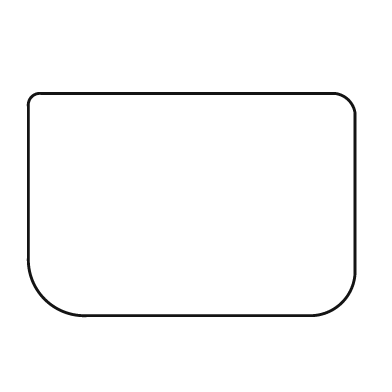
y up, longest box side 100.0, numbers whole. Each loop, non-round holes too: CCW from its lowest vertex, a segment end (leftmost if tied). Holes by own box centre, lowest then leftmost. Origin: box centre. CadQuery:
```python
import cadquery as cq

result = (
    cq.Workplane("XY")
    .moveTo(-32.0, -34.0)
    .lineTo(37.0, -34.0)
    .threePointArc((46.0, -30.0), (50.0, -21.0))
    .lineTo(50.0, 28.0)
    .threePointArc((48.0, 32.0), (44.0, 34.0))
    .lineTo(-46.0, 34.0)
    .threePointArc((-49.0, 33.0), (-50.0, 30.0))
    .lineTo(-50.0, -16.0)
    .threePointArc((-45.0, -29.0), (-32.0, -34.0))
    .close()
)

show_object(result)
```